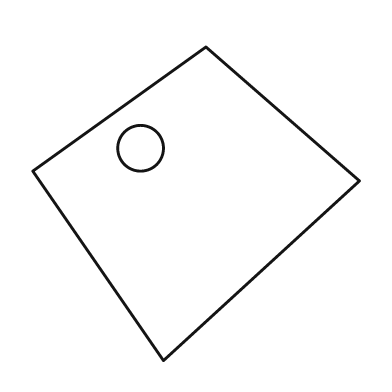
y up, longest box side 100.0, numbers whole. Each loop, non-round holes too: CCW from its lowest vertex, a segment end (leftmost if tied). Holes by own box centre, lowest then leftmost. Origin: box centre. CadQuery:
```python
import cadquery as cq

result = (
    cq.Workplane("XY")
    .moveTo(-10.0, -48.0)
    .lineTo(50.0, 7.0)
    .lineTo(3.0, 48.0)
    .lineTo(-50.0, 10.0)
    .close()
    .moveTo(-17.0, 17.0)
    .circle(7.0)
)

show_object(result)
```